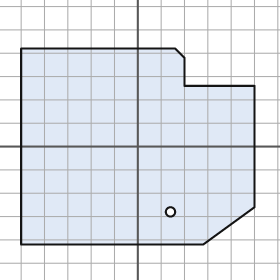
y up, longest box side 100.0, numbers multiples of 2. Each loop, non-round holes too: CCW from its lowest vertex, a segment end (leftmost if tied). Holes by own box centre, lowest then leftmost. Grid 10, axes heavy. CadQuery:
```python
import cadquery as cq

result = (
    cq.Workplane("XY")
    .moveTo(-50.0, -42.0)
    .lineTo(28.0, -42.0)
    .lineTo(50.0, -26.0)
    .lineTo(50.0, 26.0)
    .lineTo(20.0, 26.0)
    .lineTo(20.0, 38.0)
    .lineTo(16.0, 42.0)
    .lineTo(-50.0, 42.0)
    .close()
    .moveTo(14.0, -28.0)
    .circle(2.0)
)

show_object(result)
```